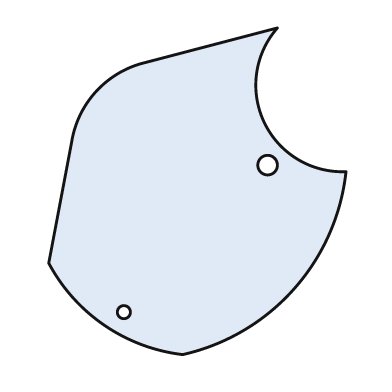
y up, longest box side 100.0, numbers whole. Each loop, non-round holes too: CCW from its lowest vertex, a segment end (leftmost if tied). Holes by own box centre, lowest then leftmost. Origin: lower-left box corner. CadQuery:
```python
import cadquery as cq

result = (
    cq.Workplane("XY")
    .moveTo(41.0, 0.0)
    .threePointArc((75.0, 20.0), (91.0, 56.0))
    .threePointArc((66.0, 71.0), (70.0, 100.0))
    .lineTo(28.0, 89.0)
    .threePointArc((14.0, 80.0), (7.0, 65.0))
    .lineTo(0.0, 28.0)
    .threePointArc((17.0, 9.0), (41.0, 0.0))
    .close()
    .moveTo(23.0, 13.0)
    .circle(2.0)
    .moveTo(67.0, 58.0)
    .circle(3.0)
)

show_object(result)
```